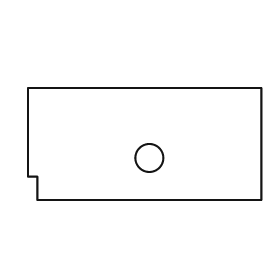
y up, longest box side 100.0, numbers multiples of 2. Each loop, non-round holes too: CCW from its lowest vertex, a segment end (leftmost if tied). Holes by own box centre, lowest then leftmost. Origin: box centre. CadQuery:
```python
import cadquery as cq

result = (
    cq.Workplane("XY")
    .moveTo(-46.0, -24.0)
    .lineTo(50.0, -24.0)
    .lineTo(50.0, 24.0)
    .lineTo(-50.0, 24.0)
    .lineTo(-50.0, -14.0)
    .lineTo(-46.0, -14.0)
    .close()
    .moveTo(2.0, -6.0)
    .circle(6.0)
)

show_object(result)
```